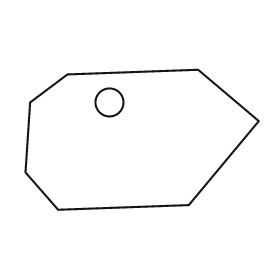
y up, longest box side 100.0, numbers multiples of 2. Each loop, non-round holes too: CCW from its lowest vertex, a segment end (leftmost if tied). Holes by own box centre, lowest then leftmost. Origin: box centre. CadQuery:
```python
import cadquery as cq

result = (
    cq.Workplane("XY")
    .moveTo(-36.0, -30.0)
    .lineTo(20.0, -28.0)
    .lineTo(50.0, 8.0)
    .lineTo(24.0, 30.0)
    .lineTo(-32.0, 28.0)
    .lineTo(-48.0, 16.0)
    .lineTo(-50.0, -14.0)
    .close()
    .moveTo(-14.0, 16.0)
    .circle(6.0)
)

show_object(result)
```